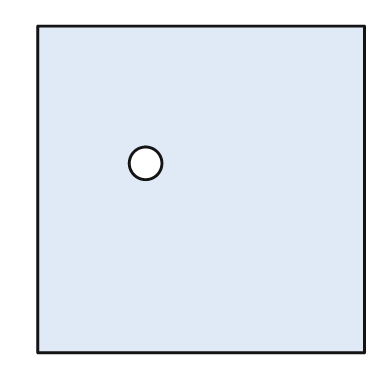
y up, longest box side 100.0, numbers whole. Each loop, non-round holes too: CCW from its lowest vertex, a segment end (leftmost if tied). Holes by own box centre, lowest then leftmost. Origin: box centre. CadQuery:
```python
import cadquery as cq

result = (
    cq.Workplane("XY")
    .moveTo(-50.0, -50.0)
    .lineTo(50.0, -50.0)
    .lineTo(50.0, 50.0)
    .lineTo(-50.0, 50.0)
    .close()
    .moveTo(-17.0, 8.0)
    .circle(5.0)
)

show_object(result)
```